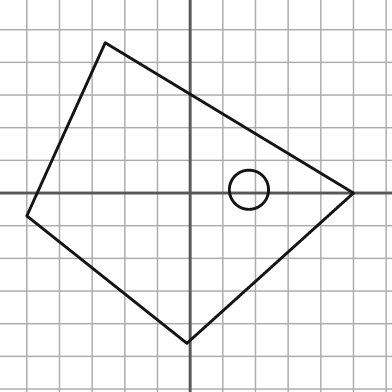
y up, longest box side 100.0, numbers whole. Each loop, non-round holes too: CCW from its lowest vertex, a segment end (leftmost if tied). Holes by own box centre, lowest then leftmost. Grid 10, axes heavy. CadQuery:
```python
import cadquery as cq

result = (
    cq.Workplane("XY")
    .moveTo(-1.0, -46.0)
    .lineTo(50.0, 0.0)
    .lineTo(-26.0, 46.0)
    .lineTo(-50.0, -7.0)
    .close()
    .moveTo(18.0, 1.0)
    .circle(6.0)
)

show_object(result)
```